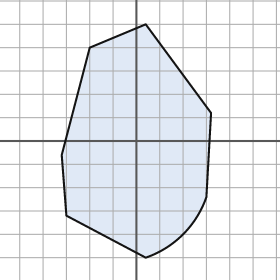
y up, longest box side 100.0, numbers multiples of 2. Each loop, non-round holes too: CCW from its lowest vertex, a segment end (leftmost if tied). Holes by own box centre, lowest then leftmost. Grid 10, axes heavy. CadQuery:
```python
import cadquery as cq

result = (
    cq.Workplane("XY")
    .moveTo(4.0, -50.0)
    .threePointArc((20.0, -40.0), (30.0, -24.0))
    .lineTo(32.0, 12.0)
    .lineTo(4.0, 50.0)
    .lineTo(-20.0, 40.0)
    .lineTo(-32.0, -6.0)
    .lineTo(-30.0, -32.0)
    .close()
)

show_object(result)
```